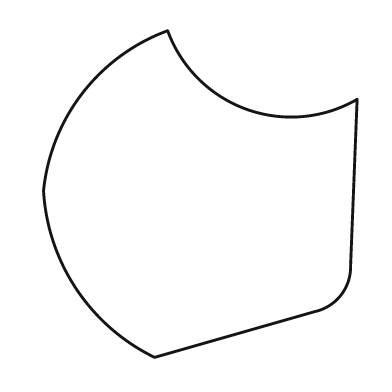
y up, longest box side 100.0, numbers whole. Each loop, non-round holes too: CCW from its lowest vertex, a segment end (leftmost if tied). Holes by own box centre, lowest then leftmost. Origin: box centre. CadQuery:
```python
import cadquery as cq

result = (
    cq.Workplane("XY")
    .moveTo(-14.0, -50.0)
    .lineTo(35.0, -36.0)
    .threePointArc((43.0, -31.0), (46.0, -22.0))
    .lineTo(48.0, 29.0)
    .threePointArc((14.0, 26.0), (-10.0, 50.0))
    .threePointArc((-36.0, 31.0), (-48.0, 1.0))
    .threePointArc((-38.0, -29.0), (-14.0, -50.0))
    .close()
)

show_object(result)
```